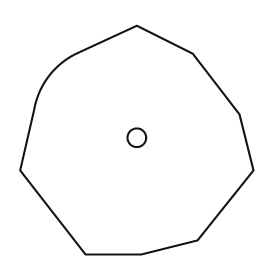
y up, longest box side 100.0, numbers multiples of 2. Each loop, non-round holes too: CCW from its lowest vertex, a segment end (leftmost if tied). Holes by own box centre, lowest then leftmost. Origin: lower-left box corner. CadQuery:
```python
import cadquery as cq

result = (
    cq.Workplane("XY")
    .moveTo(28.0, 0.0)
    .lineTo(52.0, 0.0)
    .lineTo(76.0, 6.0)
    .lineTo(100.0, 36.0)
    .lineTo(94.0, 60.0)
    .lineTo(74.0, 86.0)
    .lineTo(50.0, 98.0)
    .lineTo(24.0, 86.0)
    .threePointArc((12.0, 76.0), (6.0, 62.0))
    .lineTo(0.0, 36.0)
    .close()
    .moveTo(50.0, 50.0)
    .circle(4.0)
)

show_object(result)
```